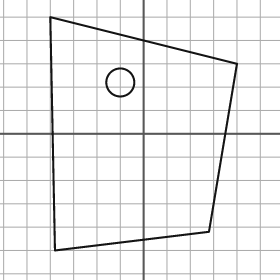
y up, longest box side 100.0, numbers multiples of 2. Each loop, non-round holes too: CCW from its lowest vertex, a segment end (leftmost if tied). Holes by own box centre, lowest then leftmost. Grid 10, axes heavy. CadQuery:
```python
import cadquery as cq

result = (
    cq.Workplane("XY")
    .moveTo(-38.0, -50.0)
    .lineTo(28.0, -42.0)
    .lineTo(40.0, 30.0)
    .lineTo(-40.0, 50.0)
    .close()
    .moveTo(-10.0, 22.0)
    .circle(6.0)
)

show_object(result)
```